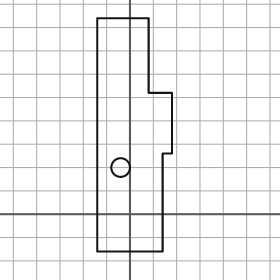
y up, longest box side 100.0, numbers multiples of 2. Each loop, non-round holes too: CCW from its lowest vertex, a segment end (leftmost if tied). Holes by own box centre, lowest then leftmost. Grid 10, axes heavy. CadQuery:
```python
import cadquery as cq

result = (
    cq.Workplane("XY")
    .moveTo(-14.0, -16.0)
    .lineTo(14.0, -16.0)
    .lineTo(14.0, 26.0)
    .lineTo(18.0, 26.0)
    .lineTo(18.0, 52.0)
    .lineTo(8.0, 52.0)
    .lineTo(8.0, 84.0)
    .lineTo(-14.0, 84.0)
    .close()
    .moveTo(-4.0, 20.0)
    .circle(4.0)
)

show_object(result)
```